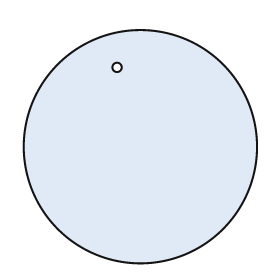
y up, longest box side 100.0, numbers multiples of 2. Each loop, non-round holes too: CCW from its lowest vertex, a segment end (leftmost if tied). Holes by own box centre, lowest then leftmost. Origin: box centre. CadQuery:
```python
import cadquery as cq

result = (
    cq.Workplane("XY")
    .moveTo(0.0, 0.0)
    .circle(50.0)
    .moveTo(-10.0, 34.0)
    .circle(2.0)
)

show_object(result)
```